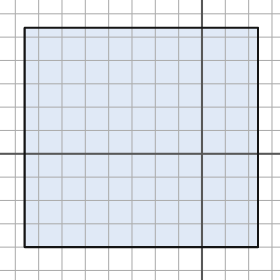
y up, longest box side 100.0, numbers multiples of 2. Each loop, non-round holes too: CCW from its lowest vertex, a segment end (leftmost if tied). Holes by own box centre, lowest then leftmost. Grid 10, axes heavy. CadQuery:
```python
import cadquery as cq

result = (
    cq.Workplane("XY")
    .moveTo(-76.0, -40.0)
    .lineTo(24.0, -40.0)
    .lineTo(24.0, 54.0)
    .lineTo(-76.0, 54.0)
    .close()
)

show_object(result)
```